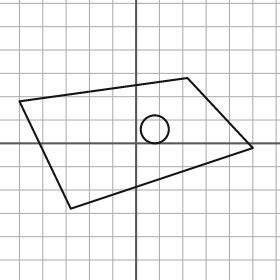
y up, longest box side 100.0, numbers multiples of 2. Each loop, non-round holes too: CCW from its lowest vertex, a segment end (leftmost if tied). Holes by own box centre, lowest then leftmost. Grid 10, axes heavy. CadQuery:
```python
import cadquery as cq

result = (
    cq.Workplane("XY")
    .moveTo(-28.0, -28.0)
    .lineTo(50.0, -2.0)
    .lineTo(22.0, 28.0)
    .lineTo(-50.0, 18.0)
    .close()
    .moveTo(8.0, 6.0)
    .circle(6.0)
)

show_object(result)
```